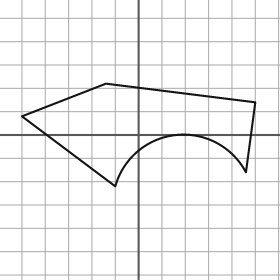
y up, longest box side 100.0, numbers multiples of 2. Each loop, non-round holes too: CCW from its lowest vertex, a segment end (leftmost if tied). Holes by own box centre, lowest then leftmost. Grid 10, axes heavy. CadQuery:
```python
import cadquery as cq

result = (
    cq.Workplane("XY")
    .moveTo(-10.0, -22.0)
    .threePointArc((16.0, 0.0), (46.0, -16.0))
    .lineTo(50.0, 14.0)
    .lineTo(-14.0, 22.0)
    .lineTo(-50.0, 8.0)
    .close()
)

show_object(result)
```